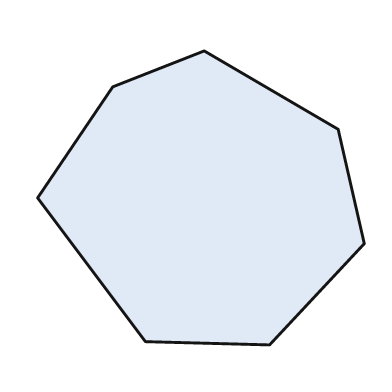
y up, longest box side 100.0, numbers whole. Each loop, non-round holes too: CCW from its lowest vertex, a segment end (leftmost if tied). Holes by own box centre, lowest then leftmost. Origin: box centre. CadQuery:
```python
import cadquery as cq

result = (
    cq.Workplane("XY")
    .moveTo(21.0, -45.0)
    .lineTo(50.0, -14.0)
    .lineTo(42.0, 21.0)
    .lineTo(1.0, 45.0)
    .lineTo(-27.0, 34.0)
    .lineTo(-50.0, 0.0)
    .lineTo(-17.0, -44.0)
    .close()
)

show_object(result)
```